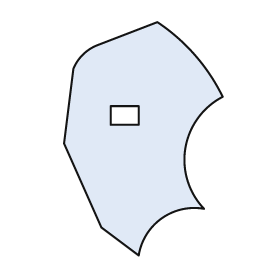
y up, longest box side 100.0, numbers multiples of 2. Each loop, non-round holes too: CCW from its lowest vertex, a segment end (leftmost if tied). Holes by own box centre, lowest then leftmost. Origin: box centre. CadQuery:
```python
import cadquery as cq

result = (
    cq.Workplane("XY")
    .moveTo(-2.0, -50.0)
    .threePointArc((8.0, -34.0), (26.0, -30.0))
    .threePointArc((18.0, -4.0), (34.0, 18.0))
    .threePointArc((22.0, 36.0), (6.0, 50.0))
    .lineTo(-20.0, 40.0)
    .threePointArc((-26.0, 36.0), (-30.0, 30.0))
    .lineTo(-34.0, -2.0)
    .lineTo(-18.0, -38.0)
    .close()
    .moveTo(-14.0, 6.0)
    .lineTo(-2.0, 6.0)
    .lineTo(-2.0, 14.0)
    .lineTo(-14.0, 14.0)
    .close()
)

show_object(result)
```